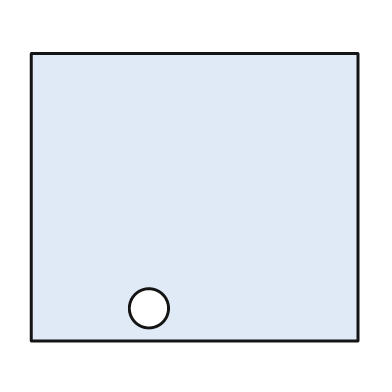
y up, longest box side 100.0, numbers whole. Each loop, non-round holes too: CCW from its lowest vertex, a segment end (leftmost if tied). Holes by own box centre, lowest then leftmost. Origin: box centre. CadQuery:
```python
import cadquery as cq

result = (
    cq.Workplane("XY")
    .moveTo(-50.0, -44.0)
    .lineTo(50.0, -44.0)
    .lineTo(50.0, 44.0)
    .lineTo(-50.0, 44.0)
    .close()
    .moveTo(-14.0, -34.0)
    .circle(6.0)
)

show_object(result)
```